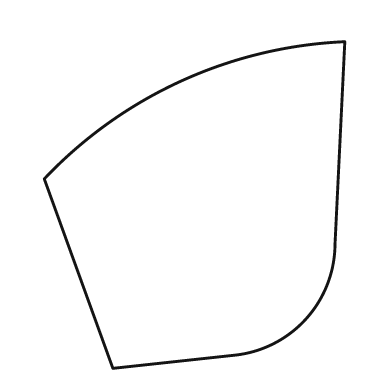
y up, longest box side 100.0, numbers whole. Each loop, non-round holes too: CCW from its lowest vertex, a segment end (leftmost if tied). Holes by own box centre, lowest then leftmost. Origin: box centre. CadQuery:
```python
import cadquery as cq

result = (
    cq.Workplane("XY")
    .moveTo(-25.0, -50.0)
    .lineTo(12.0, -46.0)
    .threePointArc((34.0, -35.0), (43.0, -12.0))
    .lineTo(46.0, 50.0)
    .threePointArc((-4.0, 38.0), (-46.0, 8.0))
    .close()
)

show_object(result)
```